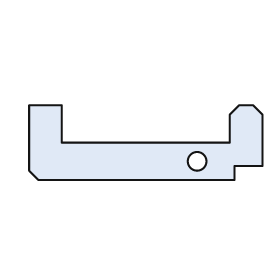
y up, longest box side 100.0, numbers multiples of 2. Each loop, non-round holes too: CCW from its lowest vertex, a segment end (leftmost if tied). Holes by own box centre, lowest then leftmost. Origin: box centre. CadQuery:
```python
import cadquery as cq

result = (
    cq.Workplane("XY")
    .moveTo(-46.0, -16.0)
    .lineTo(38.0, -16.0)
    .lineTo(38.0, -10.0)
    .lineTo(50.0, -10.0)
    .lineTo(50.0, 12.0)
    .lineTo(46.0, 16.0)
    .lineTo(40.0, 16.0)
    .lineTo(36.0, 12.0)
    .lineTo(36.0, 0.0)
    .lineTo(-36.0, 0.0)
    .lineTo(-36.0, 16.0)
    .lineTo(-50.0, 16.0)
    .lineTo(-50.0, -12.0)
    .close()
    .moveTo(22.0, -8.0)
    .circle(4.0)
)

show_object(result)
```